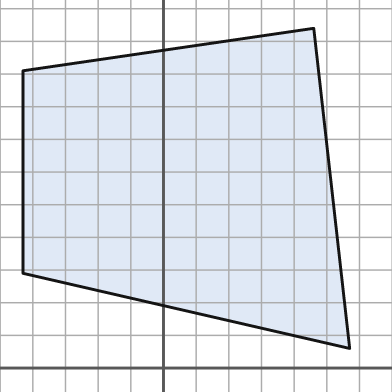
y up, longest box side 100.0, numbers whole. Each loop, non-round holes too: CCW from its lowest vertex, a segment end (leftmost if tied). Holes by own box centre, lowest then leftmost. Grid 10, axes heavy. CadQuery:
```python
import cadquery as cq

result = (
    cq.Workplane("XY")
    .moveTo(57.0, 6.0)
    .lineTo(46.0, 104.0)
    .lineTo(-43.0, 91.0)
    .lineTo(-43.0, 29.0)
    .close()
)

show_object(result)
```